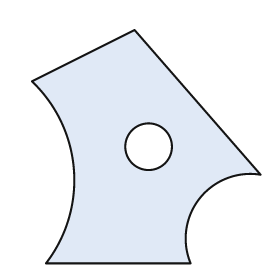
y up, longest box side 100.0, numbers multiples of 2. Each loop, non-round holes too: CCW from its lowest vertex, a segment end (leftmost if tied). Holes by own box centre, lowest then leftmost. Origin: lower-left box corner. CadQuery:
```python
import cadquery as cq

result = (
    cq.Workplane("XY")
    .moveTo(6.0, 0.0)
    .lineTo(68.0, 0.0)
    .threePointArc((72.0, 28.0), (98.0, 38.0))
    .lineTo(44.0, 100.0)
    .lineTo(0.0, 78.0)
    .threePointArc((18.0, 40.0), (6.0, 0.0))
    .close()
    .moveTo(50.0, 50.0)
    .circle(10.0)
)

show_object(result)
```